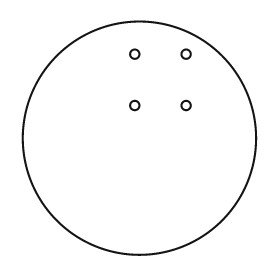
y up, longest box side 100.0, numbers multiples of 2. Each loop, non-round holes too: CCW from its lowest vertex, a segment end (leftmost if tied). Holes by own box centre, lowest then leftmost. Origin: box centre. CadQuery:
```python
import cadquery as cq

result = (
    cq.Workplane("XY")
    .moveTo(0.0, 0.0)
    .circle(50.0)
    .moveTo(-2.0, 14.0)
    .circle(2.0)
    .moveTo(20.0, 14.0)
    .circle(2.0)
    .moveTo(-2.0, 36.0)
    .circle(2.0)
    .moveTo(20.0, 36.0)
    .circle(2.0)
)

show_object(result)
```